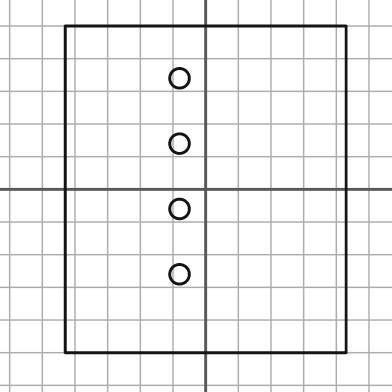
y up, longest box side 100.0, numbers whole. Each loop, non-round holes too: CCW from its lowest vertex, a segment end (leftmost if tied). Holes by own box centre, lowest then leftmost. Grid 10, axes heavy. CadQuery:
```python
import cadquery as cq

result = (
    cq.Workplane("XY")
    .moveTo(-43.0, -50.0)
    .lineTo(43.0, -50.0)
    .lineTo(43.0, 50.0)
    .lineTo(-43.0, 50.0)
    .close()
    .moveTo(-8.0, -26.0)
    .circle(3.0)
    .moveTo(-8.0, -6.0)
    .circle(3.0)
    .moveTo(-8.0, 14.0)
    .circle(3.0)
    .moveTo(-8.0, 34.0)
    .circle(3.0)
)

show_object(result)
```